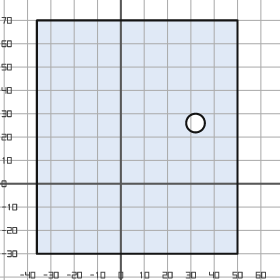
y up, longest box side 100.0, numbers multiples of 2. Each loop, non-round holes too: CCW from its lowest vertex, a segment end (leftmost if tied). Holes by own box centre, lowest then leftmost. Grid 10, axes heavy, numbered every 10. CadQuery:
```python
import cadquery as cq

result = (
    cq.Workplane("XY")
    .moveTo(-36.0, -30.0)
    .lineTo(50.0, -30.0)
    .lineTo(50.0, 70.0)
    .lineTo(-36.0, 70.0)
    .close()
    .moveTo(32.0, 26.0)
    .circle(4.0)
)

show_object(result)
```